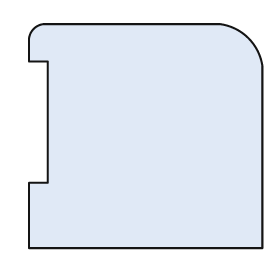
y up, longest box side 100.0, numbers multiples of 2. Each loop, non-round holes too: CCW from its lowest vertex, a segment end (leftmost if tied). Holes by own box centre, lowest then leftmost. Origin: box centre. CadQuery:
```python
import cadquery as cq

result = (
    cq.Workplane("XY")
    .moveTo(-50.0, -48.0)
    .lineTo(50.0, -48.0)
    .lineTo(50.0, 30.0)
    .threePointArc((44.0, 42.0), (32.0, 48.0))
    .lineTo(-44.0, 48.0)
    .threePointArc((-48.0, 46.0), (-50.0, 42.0))
    .lineTo(-50.0, 32.0)
    .lineTo(-42.0, 32.0)
    .lineTo(-42.0, -20.0)
    .lineTo(-50.0, -20.0)
    .close()
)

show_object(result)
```